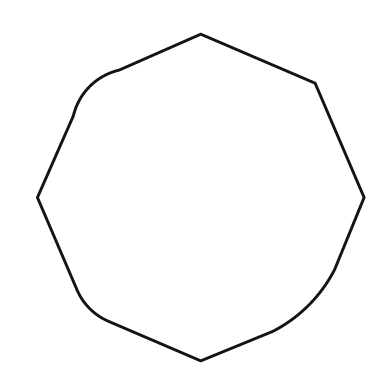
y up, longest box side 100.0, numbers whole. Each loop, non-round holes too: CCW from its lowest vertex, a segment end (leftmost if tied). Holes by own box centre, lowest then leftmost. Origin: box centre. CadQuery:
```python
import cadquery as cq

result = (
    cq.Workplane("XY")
    .moveTo(0.0, -50.0)
    .lineTo(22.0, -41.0)
    .threePointArc((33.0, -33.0), (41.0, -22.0))
    .lineTo(50.0, 0.0)
    .lineTo(35.0, 35.0)
    .lineTo(0.0, 50.0)
    .lineTo(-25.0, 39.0)
    .threePointArc((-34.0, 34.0), (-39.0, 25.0))
    .lineTo(-50.0, 0.0)
    .lineTo(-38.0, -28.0)
    .threePointArc((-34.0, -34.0), (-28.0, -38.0))
    .close()
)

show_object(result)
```